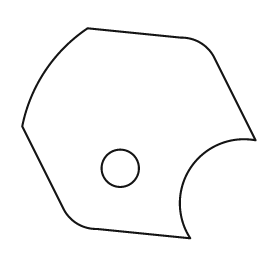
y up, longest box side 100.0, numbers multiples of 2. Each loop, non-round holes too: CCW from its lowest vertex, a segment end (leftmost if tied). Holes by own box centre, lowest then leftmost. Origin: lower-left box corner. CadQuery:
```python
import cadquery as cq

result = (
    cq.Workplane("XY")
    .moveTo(72.0, 0.0)
    .threePointArc((72.0, 30.0), (100.0, 42.0))
    .lineTo(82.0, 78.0)
    .threePointArc((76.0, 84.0), (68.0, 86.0))
    .lineTo(28.0, 90.0)
    .threePointArc((10.0, 72.0), (0.0, 48.0))
    .lineTo(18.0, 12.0)
    .threePointArc((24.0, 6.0), (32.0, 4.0))
    .close()
    .moveTo(42.0, 30.0)
    .circle(8.0)
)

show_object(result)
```